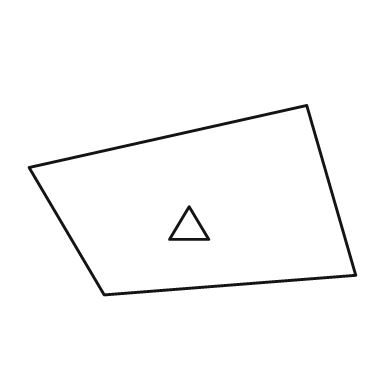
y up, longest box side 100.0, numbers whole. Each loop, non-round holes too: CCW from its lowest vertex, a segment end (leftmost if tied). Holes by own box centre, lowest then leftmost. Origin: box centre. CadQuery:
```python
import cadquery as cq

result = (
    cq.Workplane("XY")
    .moveTo(-27.0, -29.0)
    .lineTo(50.0, -23.0)
    .lineTo(35.0, 29.0)
    .lineTo(-50.0, 10.0)
    .close()
    .moveTo(-7.0, -12.0)
    .lineTo(5.0, -12.0)
    .lineTo(-1.0, -2.0)
    .close()
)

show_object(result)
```